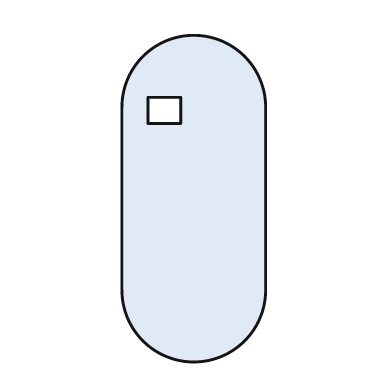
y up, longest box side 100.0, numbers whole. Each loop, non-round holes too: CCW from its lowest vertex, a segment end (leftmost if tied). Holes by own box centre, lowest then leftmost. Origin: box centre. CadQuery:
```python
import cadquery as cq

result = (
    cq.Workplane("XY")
    .moveTo(-22.0, -28.0)
    .threePointArc((0.0, -50.0), (22.0, -28.0))
    .lineTo(22.0, 28.0)
    .threePointArc((0.0, 50.0), (-22.0, 28.0))
    .close()
    .moveTo(-14.0, 23.0)
    .lineTo(-4.0, 23.0)
    .lineTo(-4.0, 31.0)
    .lineTo(-14.0, 31.0)
    .close()
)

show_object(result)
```